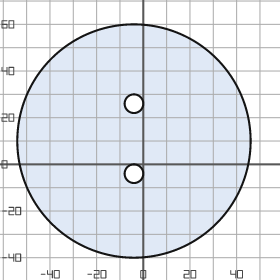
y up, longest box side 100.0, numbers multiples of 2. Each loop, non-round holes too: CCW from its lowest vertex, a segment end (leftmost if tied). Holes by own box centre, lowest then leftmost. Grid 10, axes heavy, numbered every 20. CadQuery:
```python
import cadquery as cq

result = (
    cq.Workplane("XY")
    .moveTo(-4.0, 10.0)
    .circle(50.0)
    .moveTo(-4.0, -4.0)
    .circle(4.0)
    .moveTo(-4.0, 26.0)
    .circle(4.0)
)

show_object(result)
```